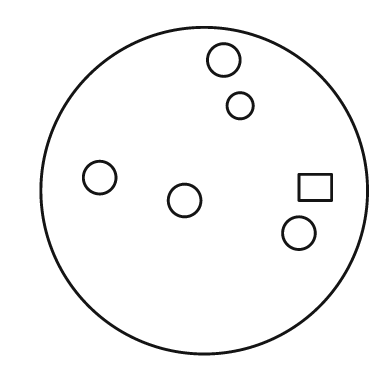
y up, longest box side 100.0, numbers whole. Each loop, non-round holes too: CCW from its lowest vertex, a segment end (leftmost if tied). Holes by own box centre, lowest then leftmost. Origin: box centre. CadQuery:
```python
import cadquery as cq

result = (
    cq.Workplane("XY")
    .moveTo(0.0, 0.0)
    .circle(50.0)
    .moveTo(29.0, -13.0)
    .circle(5.0)
    .moveTo(-6.0, -3.0)
    .circle(5.0)
    .moveTo(29.0, -3.0)
    .lineTo(39.0, -3.0)
    .lineTo(39.0, 5.0)
    .lineTo(29.0, 5.0)
    .close()
    .moveTo(-32.0, 4.0)
    .circle(5.0)
    .moveTo(11.0, 26.0)
    .circle(4.0)
    .moveTo(6.0, 40.0)
    .circle(5.0)
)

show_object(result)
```